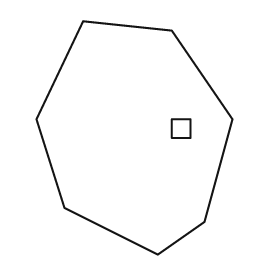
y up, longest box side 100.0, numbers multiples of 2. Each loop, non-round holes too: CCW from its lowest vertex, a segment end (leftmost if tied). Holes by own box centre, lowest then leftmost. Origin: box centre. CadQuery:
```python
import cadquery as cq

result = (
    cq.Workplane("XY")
    .moveTo(10.0, -50.0)
    .lineTo(30.0, -36.0)
    .lineTo(42.0, 8.0)
    .lineTo(16.0, 46.0)
    .lineTo(-22.0, 50.0)
    .lineTo(-42.0, 8.0)
    .lineTo(-30.0, -30.0)
    .close()
    .moveTo(16.0, 0.0)
    .lineTo(24.0, 0.0)
    .lineTo(24.0, 8.0)
    .lineTo(16.0, 8.0)
    .close()
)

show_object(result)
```